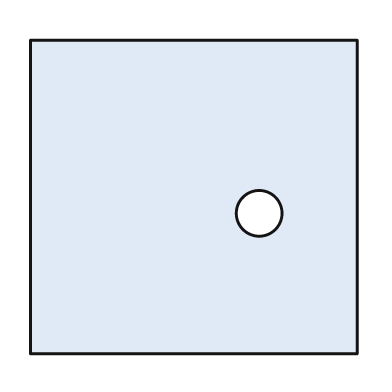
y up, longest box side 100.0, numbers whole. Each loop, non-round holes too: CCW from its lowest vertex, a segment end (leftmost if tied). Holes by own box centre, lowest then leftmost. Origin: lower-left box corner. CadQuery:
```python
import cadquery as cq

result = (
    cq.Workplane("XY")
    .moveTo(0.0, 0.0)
    .lineTo(100.0, 0.0)
    .lineTo(100.0, 96.0)
    .lineTo(0.0, 96.0)
    .close()
    .moveTo(70.0, 43.0)
    .circle(7.0)
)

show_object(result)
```